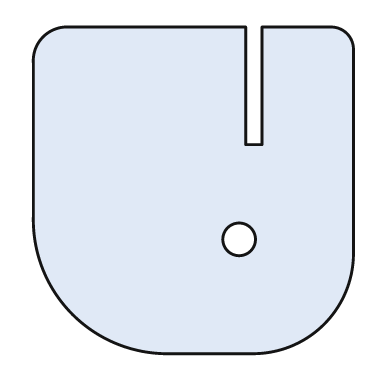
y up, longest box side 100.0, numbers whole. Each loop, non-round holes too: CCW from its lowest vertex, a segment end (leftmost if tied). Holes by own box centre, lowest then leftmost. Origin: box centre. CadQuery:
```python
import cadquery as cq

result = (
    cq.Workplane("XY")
    .moveTo(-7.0, -50.0)
    .lineTo(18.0, -50.0)
    .threePointArc((40.0, -41.0), (49.0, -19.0))
    .lineTo(49.0, 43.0)
    .threePointArc((47.0, 48.0), (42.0, 50.0))
    .lineTo(21.0, 50.0)
    .lineTo(21.0, 14.0)
    .lineTo(16.0, 14.0)
    .lineTo(16.0, 50.0)
    .lineTo(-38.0, 50.0)
    .threePointArc((-46.0, 47.0), (-49.0, 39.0))
    .lineTo(-49.0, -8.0)
    .threePointArc((-37.0, -38.0), (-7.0, -50.0))
    .close()
    .moveTo(14.0, -15.0)
    .circle(5.0)
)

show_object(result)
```